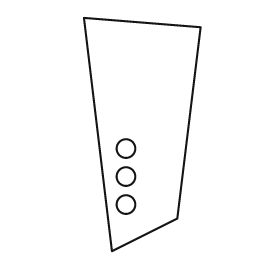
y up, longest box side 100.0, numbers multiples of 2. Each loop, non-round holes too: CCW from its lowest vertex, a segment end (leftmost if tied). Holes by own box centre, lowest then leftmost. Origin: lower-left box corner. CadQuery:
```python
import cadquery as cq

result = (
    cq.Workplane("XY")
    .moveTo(12.0, 0.0)
    .lineTo(40.0, 14.0)
    .lineTo(50.0, 96.0)
    .lineTo(0.0, 100.0)
    .close()
    .moveTo(18.0, 20.0)
    .circle(4.0)
    .moveTo(18.0, 32.0)
    .circle(4.0)
    .moveTo(18.0, 44.0)
    .circle(4.0)
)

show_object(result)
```